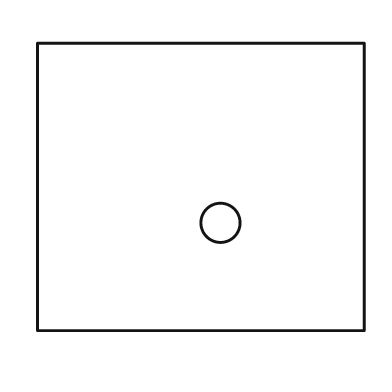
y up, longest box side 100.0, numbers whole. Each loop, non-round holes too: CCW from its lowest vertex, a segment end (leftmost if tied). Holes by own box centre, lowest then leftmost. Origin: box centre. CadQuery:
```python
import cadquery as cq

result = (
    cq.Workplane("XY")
    .moveTo(-50.0, -44.0)
    .lineTo(50.0, -44.0)
    .lineTo(50.0, 44.0)
    .lineTo(-50.0, 44.0)
    .close()
    .moveTo(6.0, -11.0)
    .circle(6.0)
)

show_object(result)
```